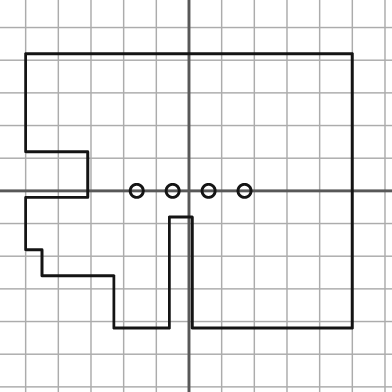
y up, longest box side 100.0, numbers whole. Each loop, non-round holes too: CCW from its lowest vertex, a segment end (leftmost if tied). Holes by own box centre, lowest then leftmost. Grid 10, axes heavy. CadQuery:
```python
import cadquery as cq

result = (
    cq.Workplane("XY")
    .moveTo(-23.0, -42.0)
    .lineTo(-6.0, -42.0)
    .lineTo(-6.0, -8.0)
    .lineTo(1.0, -8.0)
    .lineTo(1.0, -42.0)
    .lineTo(50.0, -42.0)
    .lineTo(50.0, 42.0)
    .lineTo(-50.0, 42.0)
    .lineTo(-50.0, 12.0)
    .lineTo(-31.0, 12.0)
    .lineTo(-31.0, -2.0)
    .lineTo(-50.0, -2.0)
    .lineTo(-50.0, -18.0)
    .lineTo(-45.0, -18.0)
    .lineTo(-45.0, -26.0)
    .lineTo(-23.0, -26.0)
    .close()
    .moveTo(-16.0, 0.0)
    .circle(2.0)
    .moveTo(-5.0, 0.0)
    .circle(2.0)
    .moveTo(6.0, 0.0)
    .circle(2.0)
    .moveTo(17.0, 0.0)
    .circle(2.0)
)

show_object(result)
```